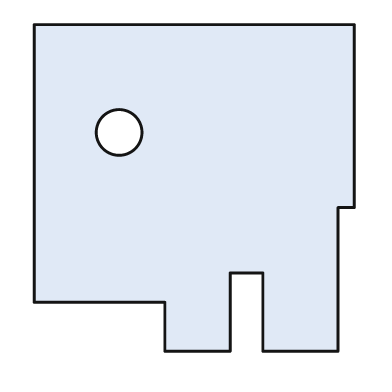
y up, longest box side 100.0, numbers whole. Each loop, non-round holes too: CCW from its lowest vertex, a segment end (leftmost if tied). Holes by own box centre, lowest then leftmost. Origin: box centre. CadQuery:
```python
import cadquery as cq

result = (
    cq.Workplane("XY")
    .moveTo(-9.0, -50.0)
    .lineTo(11.0, -50.0)
    .lineTo(11.0, -26.0)
    .lineTo(21.0, -26.0)
    .lineTo(21.0, -50.0)
    .lineTo(44.0, -50.0)
    .lineTo(44.0, -6.0)
    .lineTo(49.0, -6.0)
    .lineTo(49.0, 50.0)
    .lineTo(-49.0, 50.0)
    .lineTo(-49.0, -35.0)
    .lineTo(-9.0, -35.0)
    .close()
    .moveTo(-23.0, 17.0)
    .circle(7.0)
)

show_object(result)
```